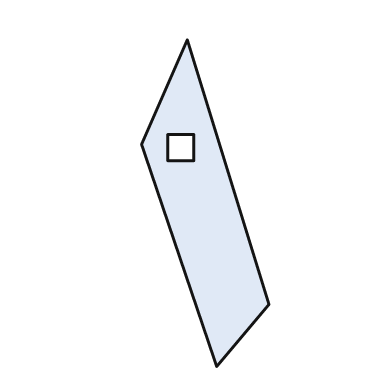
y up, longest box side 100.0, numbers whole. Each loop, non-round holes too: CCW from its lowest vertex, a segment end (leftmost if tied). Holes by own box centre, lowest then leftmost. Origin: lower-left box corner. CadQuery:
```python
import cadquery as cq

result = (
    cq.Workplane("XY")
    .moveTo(23.0, 0.0)
    .lineTo(39.0, 19.0)
    .lineTo(14.0, 100.0)
    .lineTo(0.0, 68.0)
    .close()
    .moveTo(8.0, 63.0)
    .lineTo(16.0, 63.0)
    .lineTo(16.0, 71.0)
    .lineTo(8.0, 71.0)
    .close()
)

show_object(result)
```